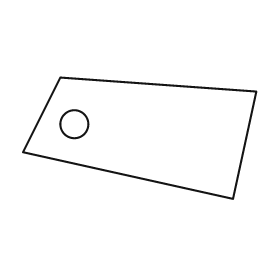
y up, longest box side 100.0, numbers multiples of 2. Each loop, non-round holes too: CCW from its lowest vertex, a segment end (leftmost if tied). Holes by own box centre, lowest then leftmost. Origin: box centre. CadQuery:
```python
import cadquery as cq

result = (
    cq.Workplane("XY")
    .moveTo(40.0, -26.0)
    .lineTo(50.0, 20.0)
    .lineTo(-34.0, 26.0)
    .lineTo(-50.0, -6.0)
    .close()
    .moveTo(-28.0, 6.0)
    .circle(6.0)
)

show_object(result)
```